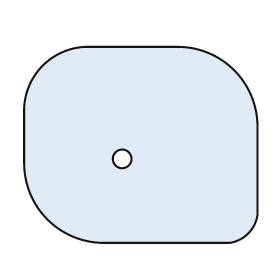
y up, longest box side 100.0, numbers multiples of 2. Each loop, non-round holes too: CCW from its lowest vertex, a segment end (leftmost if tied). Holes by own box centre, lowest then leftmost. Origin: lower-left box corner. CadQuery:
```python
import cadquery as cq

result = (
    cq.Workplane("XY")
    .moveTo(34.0, 0.0)
    .lineTo(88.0, 0.0)
    .threePointArc((96.0, 4.0), (100.0, 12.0))
    .lineTo(100.0, 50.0)
    .threePointArc((90.0, 74.0), (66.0, 84.0))
    .lineTo(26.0, 84.0)
    .threePointArc((8.0, 76.0), (0.0, 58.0))
    .lineTo(0.0, 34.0)
    .threePointArc((10.0, 10.0), (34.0, 0.0))
    .close()
    .moveTo(42.0, 36.0)
    .circle(4.0)
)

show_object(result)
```